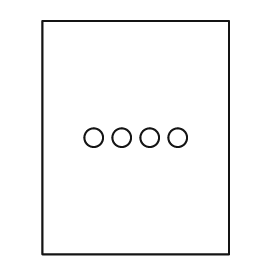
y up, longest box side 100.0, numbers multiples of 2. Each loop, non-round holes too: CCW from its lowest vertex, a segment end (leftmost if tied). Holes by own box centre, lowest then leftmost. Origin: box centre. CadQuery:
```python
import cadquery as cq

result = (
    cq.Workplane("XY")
    .moveTo(-40.0, -50.0)
    .lineTo(40.0, -50.0)
    .lineTo(40.0, 50.0)
    .lineTo(-40.0, 50.0)
    .close()
    .moveTo(-18.0, 0.0)
    .circle(4.0)
    .moveTo(-6.0, 0.0)
    .circle(4.0)
    .moveTo(6.0, 0.0)
    .circle(4.0)
    .moveTo(18.0, 0.0)
    .circle(4.0)
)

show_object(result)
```